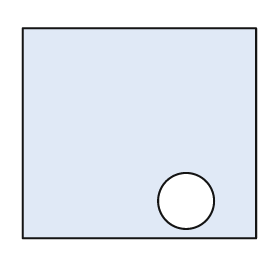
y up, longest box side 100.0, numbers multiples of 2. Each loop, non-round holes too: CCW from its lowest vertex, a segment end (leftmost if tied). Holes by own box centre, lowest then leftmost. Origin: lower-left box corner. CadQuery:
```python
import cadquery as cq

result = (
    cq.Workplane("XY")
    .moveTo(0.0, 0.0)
    .lineTo(100.0, 0.0)
    .lineTo(100.0, 90.0)
    .lineTo(0.0, 90.0)
    .close()
    .moveTo(70.0, 16.0)
    .circle(12.0)
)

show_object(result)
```